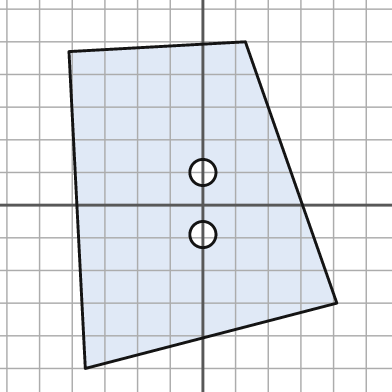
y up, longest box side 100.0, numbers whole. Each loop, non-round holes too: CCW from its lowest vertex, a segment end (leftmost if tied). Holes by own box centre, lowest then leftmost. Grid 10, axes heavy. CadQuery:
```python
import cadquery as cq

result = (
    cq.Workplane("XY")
    .moveTo(-36.0, -50.0)
    .lineTo(41.0, -30.0)
    .lineTo(13.0, 50.0)
    .lineTo(-41.0, 47.0)
    .close()
    .moveTo(0.0, -9.0)
    .circle(4.0)
    .moveTo(0.0, 10.0)
    .circle(4.0)
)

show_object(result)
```